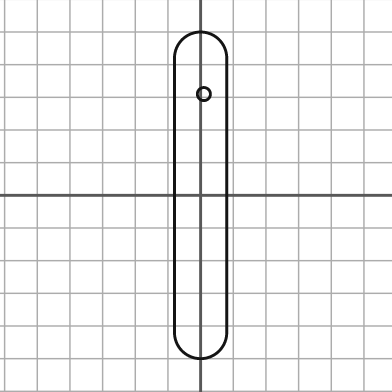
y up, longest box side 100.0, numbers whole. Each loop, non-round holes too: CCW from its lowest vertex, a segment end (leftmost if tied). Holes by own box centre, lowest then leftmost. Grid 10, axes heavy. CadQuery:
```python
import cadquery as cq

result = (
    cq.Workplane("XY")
    .moveTo(-8.0, -42.0)
    .threePointArc((0.0, -50.0), (8.0, -42.0))
    .lineTo(8.0, 42.0)
    .threePointArc((0.0, 50.0), (-8.0, 42.0))
    .close()
    .moveTo(1.0, 31.0)
    .circle(2.0)
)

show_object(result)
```